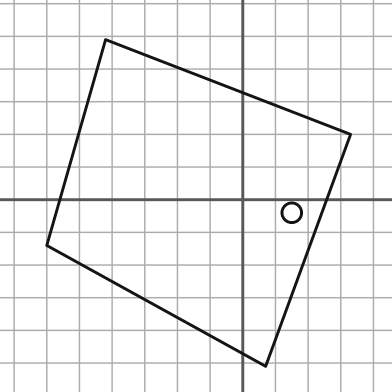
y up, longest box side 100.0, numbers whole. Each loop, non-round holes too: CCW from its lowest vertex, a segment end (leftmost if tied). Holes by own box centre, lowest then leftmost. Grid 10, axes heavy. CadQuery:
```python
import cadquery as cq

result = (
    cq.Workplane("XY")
    .moveTo(7.0, -51.0)
    .lineTo(33.0, 20.0)
    .lineTo(-42.0, 49.0)
    .lineTo(-60.0, -14.0)
    .close()
    .moveTo(15.0, -4.0)
    .circle(3.0)
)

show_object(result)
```